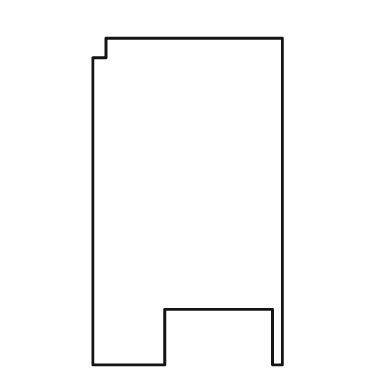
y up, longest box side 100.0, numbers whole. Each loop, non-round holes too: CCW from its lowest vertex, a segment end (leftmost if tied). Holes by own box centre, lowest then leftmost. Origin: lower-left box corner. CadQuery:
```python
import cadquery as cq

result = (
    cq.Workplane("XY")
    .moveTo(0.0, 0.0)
    .lineTo(22.0, 0.0)
    .lineTo(22.0, 17.0)
    .lineTo(55.0, 17.0)
    .lineTo(55.0, 0.0)
    .lineTo(58.0, 0.0)
    .lineTo(58.0, 100.0)
    .lineTo(4.0, 100.0)
    .lineTo(4.0, 94.0)
    .lineTo(0.0, 94.0)
    .close()
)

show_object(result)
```